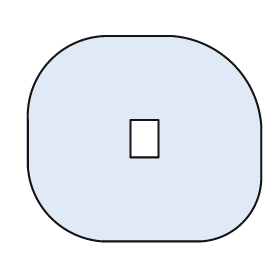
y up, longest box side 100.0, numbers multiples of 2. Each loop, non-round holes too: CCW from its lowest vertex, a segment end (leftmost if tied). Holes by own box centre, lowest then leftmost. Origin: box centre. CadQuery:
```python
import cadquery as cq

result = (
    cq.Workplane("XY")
    .moveTo(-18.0, -44.0)
    .lineTo(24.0, -44.0)
    .threePointArc((42.0, -36.0), (50.0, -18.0))
    .lineTo(50.0, 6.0)
    .threePointArc((38.0, 32.0), (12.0, 44.0))
    .lineTo(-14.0, 44.0)
    .threePointArc((-40.0, 34.0), (-50.0, 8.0))
    .lineTo(-50.0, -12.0)
    .threePointArc((-40.0, -34.0), (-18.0, -44.0))
    .close()
    .moveTo(-6.0, -8.0)
    .lineTo(6.0, -8.0)
    .lineTo(6.0, 8.0)
    .lineTo(-6.0, 8.0)
    .close()
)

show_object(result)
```